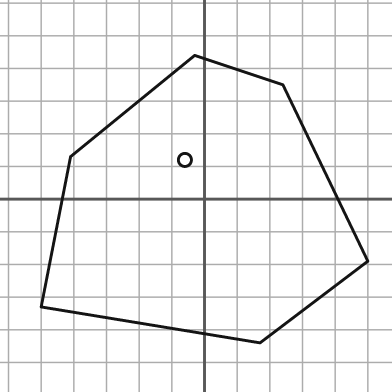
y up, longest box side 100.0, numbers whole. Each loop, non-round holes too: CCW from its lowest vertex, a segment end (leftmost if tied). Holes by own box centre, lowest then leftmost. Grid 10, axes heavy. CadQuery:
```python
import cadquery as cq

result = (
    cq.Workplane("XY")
    .moveTo(17.0, -44.0)
    .lineTo(50.0, -19.0)
    .lineTo(24.0, 35.0)
    .lineTo(-3.0, 44.0)
    .lineTo(-41.0, 13.0)
    .lineTo(-50.0, -33.0)
    .close()
    .moveTo(-6.0, 12.0)
    .circle(2.0)
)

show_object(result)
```